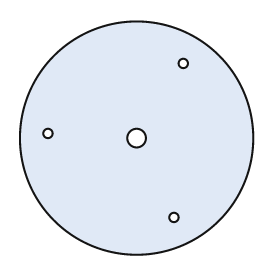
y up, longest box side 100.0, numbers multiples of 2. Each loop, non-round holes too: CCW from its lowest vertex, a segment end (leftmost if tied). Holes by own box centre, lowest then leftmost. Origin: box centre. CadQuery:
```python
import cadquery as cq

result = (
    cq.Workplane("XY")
    .moveTo(0.0, 0.0)
    .circle(50.0)
    .moveTo(16.0, -34.0)
    .circle(2.0)
    .moveTo(0.0, 0.0)
    .circle(4.0)
    .moveTo(-38.0, 2.0)
    .circle(2.0)
    .moveTo(20.0, 32.0)
    .circle(2.0)
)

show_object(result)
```